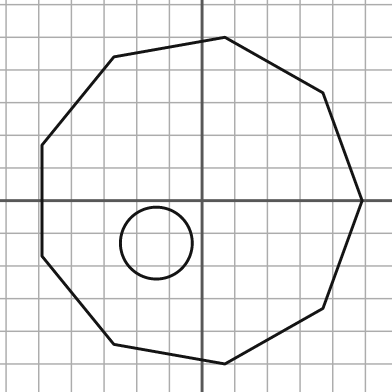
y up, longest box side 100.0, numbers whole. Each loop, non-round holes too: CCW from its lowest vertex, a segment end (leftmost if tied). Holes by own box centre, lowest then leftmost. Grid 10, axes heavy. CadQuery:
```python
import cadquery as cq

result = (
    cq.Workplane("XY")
    .moveTo(7.0, -50.0)
    .lineTo(37.0, -33.0)
    .lineTo(49.0, 0.0)
    .lineTo(37.0, 33.0)
    .lineTo(7.0, 50.0)
    .lineTo(-27.0, 44.0)
    .lineTo(-49.0, 17.0)
    .lineTo(-49.0, -17.0)
    .lineTo(-27.0, -44.0)
    .close()
    .moveTo(-14.0, -13.0)
    .circle(11.0)
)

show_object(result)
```